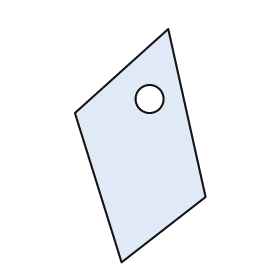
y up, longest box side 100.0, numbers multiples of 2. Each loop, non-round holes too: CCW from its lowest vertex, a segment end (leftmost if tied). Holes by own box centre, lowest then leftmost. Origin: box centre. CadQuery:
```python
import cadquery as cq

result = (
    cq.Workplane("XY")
    .moveTo(-8.0, -50.0)
    .lineTo(28.0, -22.0)
    .lineTo(12.0, 50.0)
    .lineTo(-28.0, 14.0)
    .close()
    .moveTo(4.0, 20.0)
    .circle(6.0)
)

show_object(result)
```